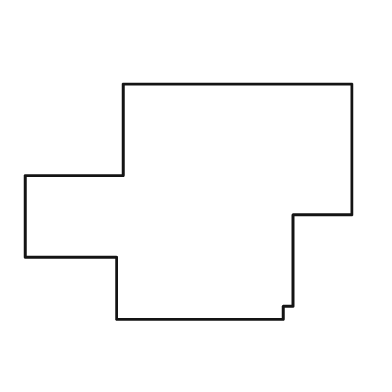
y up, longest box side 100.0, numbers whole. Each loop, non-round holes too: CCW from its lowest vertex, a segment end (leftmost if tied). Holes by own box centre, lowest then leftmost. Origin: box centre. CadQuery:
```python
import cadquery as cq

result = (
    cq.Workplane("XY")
    .moveTo(-22.0, -36.0)
    .lineTo(29.0, -36.0)
    .lineTo(29.0, -32.0)
    .lineTo(32.0, -32.0)
    .lineTo(32.0, -4.0)
    .lineTo(50.0, -4.0)
    .lineTo(50.0, 36.0)
    .lineTo(-20.0, 36.0)
    .lineTo(-20.0, 8.0)
    .lineTo(-50.0, 8.0)
    .lineTo(-50.0, -17.0)
    .lineTo(-22.0, -17.0)
    .close()
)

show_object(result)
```